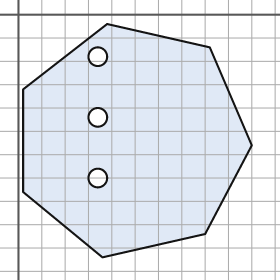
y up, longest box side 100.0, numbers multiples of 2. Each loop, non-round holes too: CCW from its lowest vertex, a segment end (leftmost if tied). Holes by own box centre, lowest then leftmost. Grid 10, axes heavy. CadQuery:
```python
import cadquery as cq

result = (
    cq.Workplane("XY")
    .moveTo(36.0, -104.0)
    .lineTo(80.0, -94.0)
    .lineTo(100.0, -56.0)
    .lineTo(82.0, -14.0)
    .lineTo(38.0, -4.0)
    .lineTo(2.0, -32.0)
    .lineTo(2.0, -76.0)
    .close()
    .moveTo(34.0, -70.0)
    .circle(4.0)
    .moveTo(34.0, -44.0)
    .circle(4.0)
    .moveTo(34.0, -18.0)
    .circle(4.0)
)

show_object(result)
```